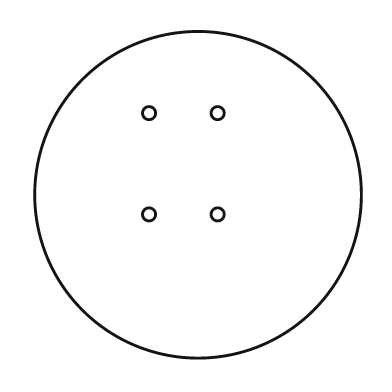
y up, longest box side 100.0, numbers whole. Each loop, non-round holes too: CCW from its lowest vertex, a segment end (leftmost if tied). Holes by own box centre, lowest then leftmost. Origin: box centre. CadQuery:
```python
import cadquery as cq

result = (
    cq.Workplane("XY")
    .moveTo(0.0, 0.0)
    .circle(50.0)
    .moveTo(-15.0, -6.0)
    .circle(2.0)
    .moveTo(6.0, -6.0)
    .circle(2.0)
    .moveTo(-15.0, 25.0)
    .circle(2.0)
    .moveTo(6.0, 25.0)
    .circle(2.0)
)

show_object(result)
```